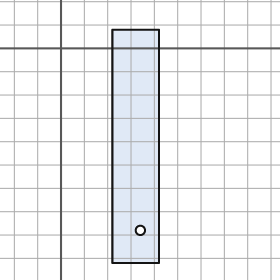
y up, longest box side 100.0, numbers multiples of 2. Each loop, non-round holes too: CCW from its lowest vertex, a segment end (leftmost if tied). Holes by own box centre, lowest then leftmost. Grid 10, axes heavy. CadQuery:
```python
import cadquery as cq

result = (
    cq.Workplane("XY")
    .moveTo(22.0, -92.0)
    .lineTo(42.0, -92.0)
    .lineTo(42.0, 8.0)
    .lineTo(22.0, 8.0)
    .close()
    .moveTo(34.0, -78.0)
    .circle(2.0)
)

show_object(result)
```